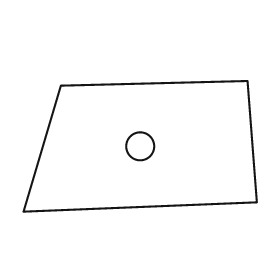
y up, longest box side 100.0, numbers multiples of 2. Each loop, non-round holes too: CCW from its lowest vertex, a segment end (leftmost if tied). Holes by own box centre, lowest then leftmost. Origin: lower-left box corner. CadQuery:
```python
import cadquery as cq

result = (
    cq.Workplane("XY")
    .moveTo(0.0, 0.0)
    .lineTo(100.0, 4.0)
    .lineTo(96.0, 56.0)
    .lineTo(16.0, 54.0)
    .close()
    .moveTo(50.0, 28.0)
    .circle(6.0)
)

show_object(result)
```